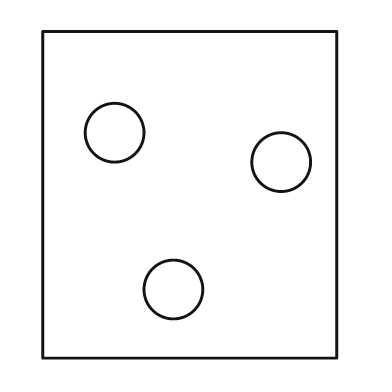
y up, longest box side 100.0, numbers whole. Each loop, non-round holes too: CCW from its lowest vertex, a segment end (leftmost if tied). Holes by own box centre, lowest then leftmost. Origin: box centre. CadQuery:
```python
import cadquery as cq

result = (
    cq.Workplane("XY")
    .moveTo(-45.0, -50.0)
    .lineTo(45.0, -50.0)
    .lineTo(45.0, 50.0)
    .lineTo(-45.0, 50.0)
    .close()
    .moveTo(-5.0, -29.0)
    .circle(9.0)
    .moveTo(28.0, 10.0)
    .circle(9.0)
    .moveTo(-23.0, 19.0)
    .circle(9.0)
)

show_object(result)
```